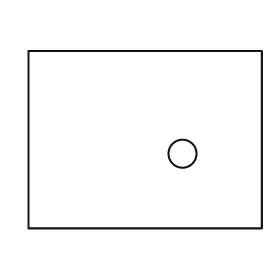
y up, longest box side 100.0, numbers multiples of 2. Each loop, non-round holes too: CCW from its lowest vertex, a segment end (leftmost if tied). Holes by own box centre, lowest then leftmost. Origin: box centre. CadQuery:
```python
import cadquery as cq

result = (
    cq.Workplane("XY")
    .moveTo(-50.0, -38.0)
    .lineTo(50.0, -38.0)
    .lineTo(50.0, 38.0)
    .lineTo(-50.0, 38.0)
    .close()
    .moveTo(16.0, -6.0)
    .circle(6.0)
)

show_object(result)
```